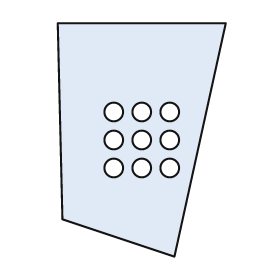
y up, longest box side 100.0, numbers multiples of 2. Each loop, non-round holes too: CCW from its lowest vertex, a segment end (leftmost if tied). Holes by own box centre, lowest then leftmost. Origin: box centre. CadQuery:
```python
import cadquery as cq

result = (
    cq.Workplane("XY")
    .moveTo(14.0, -50.0)
    .lineTo(36.0, 50.0)
    .lineTo(-36.0, 50.0)
    .lineTo(-34.0, -34.0)
    .close()
    .moveTo(-12.0, -12.0)
    .circle(4.0)
    .moveTo(0.0, -12.0)
    .circle(4.0)
    .moveTo(12.0, -12.0)
    .circle(4.0)
    .moveTo(-12.0, 0.0)
    .circle(4.0)
    .moveTo(0.0, 0.0)
    .circle(4.0)
    .moveTo(12.0, 0.0)
    .circle(4.0)
    .moveTo(-12.0, 12.0)
    .circle(4.0)
    .moveTo(0.0, 12.0)
    .circle(4.0)
    .moveTo(12.0, 12.0)
    .circle(4.0)
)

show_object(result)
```